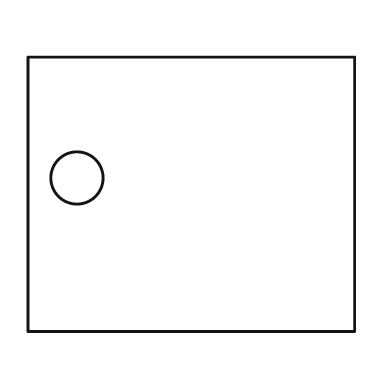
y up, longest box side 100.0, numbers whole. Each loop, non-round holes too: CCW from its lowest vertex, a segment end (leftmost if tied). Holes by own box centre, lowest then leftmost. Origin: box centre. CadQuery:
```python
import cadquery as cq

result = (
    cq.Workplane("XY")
    .moveTo(-50.0, -42.0)
    .lineTo(50.0, -42.0)
    .lineTo(50.0, 42.0)
    .lineTo(-50.0, 42.0)
    .close()
    .moveTo(-35.0, 5.0)
    .circle(8.0)
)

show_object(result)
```